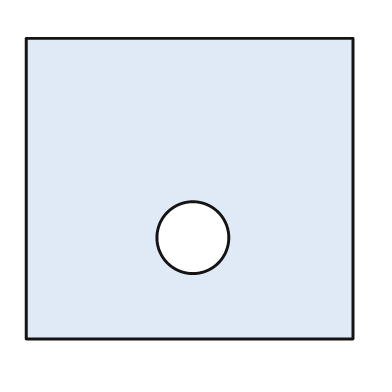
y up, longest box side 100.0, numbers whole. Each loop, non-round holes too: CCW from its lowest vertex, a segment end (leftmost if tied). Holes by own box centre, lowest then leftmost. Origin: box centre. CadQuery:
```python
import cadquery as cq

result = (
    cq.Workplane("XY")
    .moveTo(-50.0, -46.0)
    .lineTo(50.0, -46.0)
    .lineTo(50.0, 46.0)
    .lineTo(-50.0, 46.0)
    .close()
    .moveTo(1.0, -15.0)
    .circle(11.0)
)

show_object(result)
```